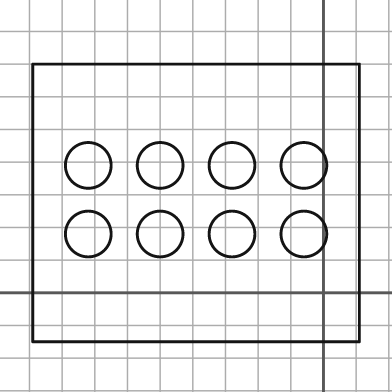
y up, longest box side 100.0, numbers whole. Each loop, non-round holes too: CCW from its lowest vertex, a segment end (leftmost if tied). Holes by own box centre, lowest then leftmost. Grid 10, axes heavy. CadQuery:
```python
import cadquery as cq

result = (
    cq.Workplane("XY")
    .moveTo(-89.0, -15.0)
    .lineTo(11.0, -15.0)
    .lineTo(11.0, 70.0)
    .lineTo(-89.0, 70.0)
    .close()
    .moveTo(-72.0, 18.0)
    .circle(7.0)
    .moveTo(-50.0, 18.0)
    .circle(7.0)
    .moveTo(-28.0, 18.0)
    .circle(7.0)
    .moveTo(-6.0, 18.0)
    .circle(7.0)
    .moveTo(-72.0, 39.0)
    .circle(7.0)
    .moveTo(-50.0, 39.0)
    .circle(7.0)
    .moveTo(-28.0, 39.0)
    .circle(7.0)
    .moveTo(-6.0, 39.0)
    .circle(7.0)
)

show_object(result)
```